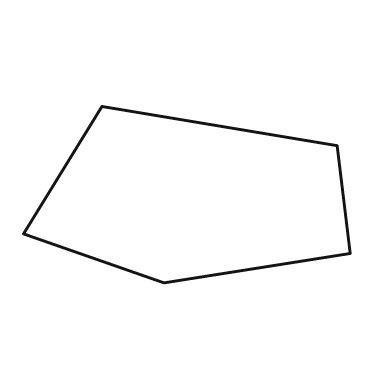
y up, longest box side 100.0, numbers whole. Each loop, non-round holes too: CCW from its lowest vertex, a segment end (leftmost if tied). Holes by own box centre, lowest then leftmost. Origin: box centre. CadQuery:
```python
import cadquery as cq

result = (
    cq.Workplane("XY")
    .moveTo(-7.0, -27.0)
    .lineTo(50.0, -18.0)
    .lineTo(46.0, 15.0)
    .lineTo(-26.0, 27.0)
    .lineTo(-50.0, -12.0)
    .close()
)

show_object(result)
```